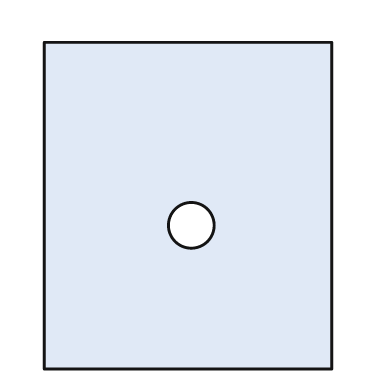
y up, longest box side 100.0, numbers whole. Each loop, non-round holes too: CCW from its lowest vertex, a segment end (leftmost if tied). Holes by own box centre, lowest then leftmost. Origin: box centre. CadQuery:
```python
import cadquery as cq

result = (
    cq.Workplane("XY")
    .moveTo(-44.0, -50.0)
    .lineTo(44.0, -50.0)
    .lineTo(44.0, 50.0)
    .lineTo(-44.0, 50.0)
    .close()
    .moveTo(1.0, -6.0)
    .circle(7.0)
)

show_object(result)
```